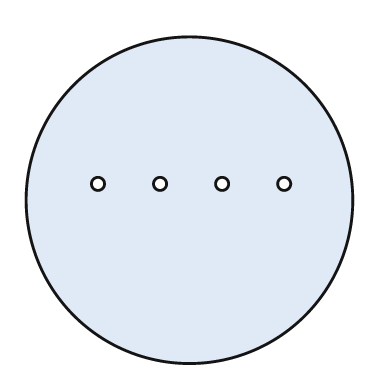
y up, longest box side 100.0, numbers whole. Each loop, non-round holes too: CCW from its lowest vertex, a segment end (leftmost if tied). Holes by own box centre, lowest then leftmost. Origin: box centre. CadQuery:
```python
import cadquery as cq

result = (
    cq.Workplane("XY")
    .moveTo(0.0, 0.0)
    .circle(50.0)
    .moveTo(-28.0, 5.0)
    .circle(2.0)
    .moveTo(-9.0, 5.0)
    .circle(2.0)
    .moveTo(10.0, 5.0)
    .circle(2.0)
    .moveTo(29.0, 5.0)
    .circle(2.0)
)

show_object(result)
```